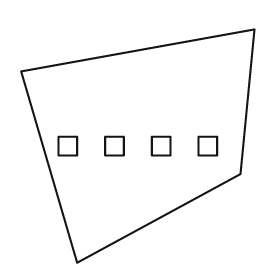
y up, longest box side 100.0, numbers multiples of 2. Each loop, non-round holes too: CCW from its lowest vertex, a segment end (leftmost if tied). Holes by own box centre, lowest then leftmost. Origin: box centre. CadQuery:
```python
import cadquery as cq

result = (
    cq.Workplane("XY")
    .moveTo(-26.0, -50.0)
    .lineTo(44.0, -12.0)
    .lineTo(50.0, 50.0)
    .lineTo(-50.0, 32.0)
    .close()
    .moveTo(-34.0, -4.0)
    .lineTo(-26.0, -4.0)
    .lineTo(-26.0, 4.0)
    .lineTo(-34.0, 4.0)
    .close()
    .moveTo(-14.0, -4.0)
    .lineTo(-6.0, -4.0)
    .lineTo(-6.0, 4.0)
    .lineTo(-14.0, 4.0)
    .close()
    .moveTo(6.0, -4.0)
    .lineTo(14.0, -4.0)
    .lineTo(14.0, 4.0)
    .lineTo(6.0, 4.0)
    .close()
    .moveTo(26.0, -4.0)
    .lineTo(34.0, -4.0)
    .lineTo(34.0, 4.0)
    .lineTo(26.0, 4.0)
    .close()
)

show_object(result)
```